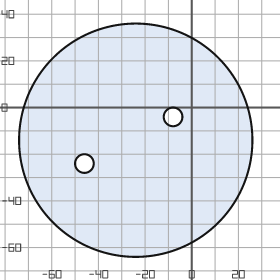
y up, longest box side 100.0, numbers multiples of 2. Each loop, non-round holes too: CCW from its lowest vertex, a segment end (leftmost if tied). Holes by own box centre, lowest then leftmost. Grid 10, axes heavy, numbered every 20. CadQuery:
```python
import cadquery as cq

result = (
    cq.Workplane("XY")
    .moveTo(-24.0, -14.0)
    .circle(50.0)
    .moveTo(-46.0, -24.0)
    .circle(4.0)
    .moveTo(-8.0, -4.0)
    .circle(4.0)
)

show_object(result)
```